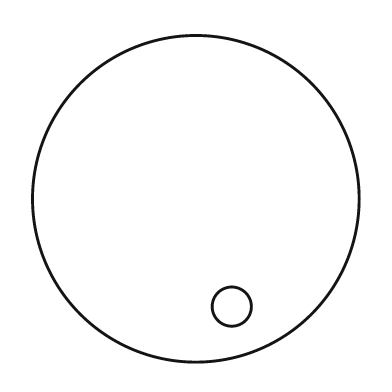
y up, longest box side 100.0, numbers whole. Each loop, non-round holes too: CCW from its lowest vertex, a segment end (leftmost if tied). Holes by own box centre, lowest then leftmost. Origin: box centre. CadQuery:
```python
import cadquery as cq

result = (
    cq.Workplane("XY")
    .moveTo(0.0, 0.0)
    .circle(50.0)
    .moveTo(11.0, -33.0)
    .circle(6.0)
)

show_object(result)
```